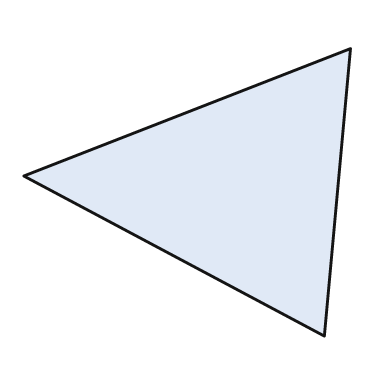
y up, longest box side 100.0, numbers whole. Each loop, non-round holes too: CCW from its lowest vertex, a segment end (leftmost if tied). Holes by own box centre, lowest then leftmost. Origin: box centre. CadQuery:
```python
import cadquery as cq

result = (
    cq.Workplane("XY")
    .moveTo(42.0, -44.0)
    .lineTo(50.0, 44.0)
    .lineTo(-50.0, 5.0)
    .close()
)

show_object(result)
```